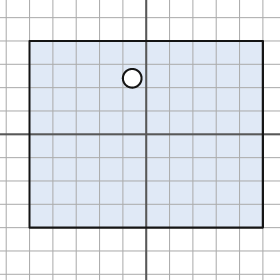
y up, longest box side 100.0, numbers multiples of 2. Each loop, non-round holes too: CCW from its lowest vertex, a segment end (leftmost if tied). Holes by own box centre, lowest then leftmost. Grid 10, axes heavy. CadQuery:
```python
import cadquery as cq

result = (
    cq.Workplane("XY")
    .moveTo(-50.0, -40.0)
    .lineTo(50.0, -40.0)
    .lineTo(50.0, 40.0)
    .lineTo(-50.0, 40.0)
    .close()
    .moveTo(-6.0, 24.0)
    .circle(4.0)
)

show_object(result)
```